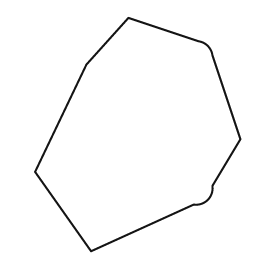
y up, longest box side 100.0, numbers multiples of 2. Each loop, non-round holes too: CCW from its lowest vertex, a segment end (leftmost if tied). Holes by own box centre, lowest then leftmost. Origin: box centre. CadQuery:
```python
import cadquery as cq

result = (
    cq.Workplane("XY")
    .moveTo(-20.0, -50.0)
    .lineTo(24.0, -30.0)
    .threePointArc((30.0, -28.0), (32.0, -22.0))
    .lineTo(44.0, -2.0)
    .lineTo(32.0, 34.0)
    .threePointArc((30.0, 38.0), (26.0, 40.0))
    .lineTo(-4.0, 50.0)
    .lineTo(-22.0, 30.0)
    .lineTo(-44.0, -16.0)
    .close()
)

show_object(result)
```